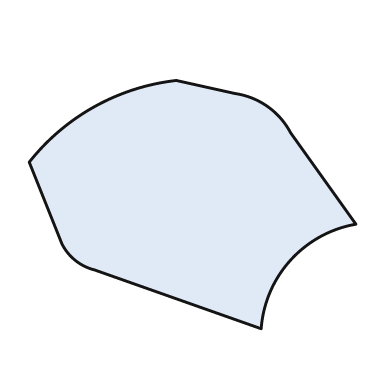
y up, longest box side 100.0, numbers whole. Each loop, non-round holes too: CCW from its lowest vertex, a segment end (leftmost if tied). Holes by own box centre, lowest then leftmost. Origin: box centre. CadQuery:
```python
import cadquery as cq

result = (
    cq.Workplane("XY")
    .moveTo(21.0, -38.0)
    .threePointArc((30.0, -17.0), (50.0, -6.0))
    .lineTo(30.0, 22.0)
    .threePointArc((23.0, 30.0), (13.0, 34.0))
    .lineTo(-5.0, 38.0)
    .threePointArc((-30.0, 30.0), (-50.0, 13.0))
    .lineTo(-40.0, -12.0)
    .threePointArc((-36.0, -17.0), (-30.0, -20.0))
    .close()
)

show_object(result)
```